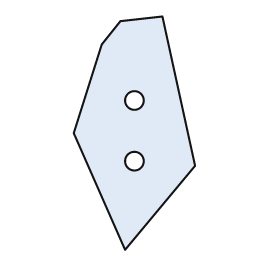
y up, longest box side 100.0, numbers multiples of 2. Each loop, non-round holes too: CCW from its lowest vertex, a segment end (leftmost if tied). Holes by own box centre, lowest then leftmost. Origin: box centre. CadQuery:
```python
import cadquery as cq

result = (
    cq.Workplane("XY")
    .moveTo(-4.0, -50.0)
    .lineTo(26.0, -14.0)
    .lineTo(12.0, 50.0)
    .lineTo(-6.0, 48.0)
    .lineTo(-14.0, 38.0)
    .lineTo(-26.0, 0.0)
    .close()
    .moveTo(0.0, -12.0)
    .circle(4.0)
    .moveTo(0.0, 14.0)
    .circle(4.0)
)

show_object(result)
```